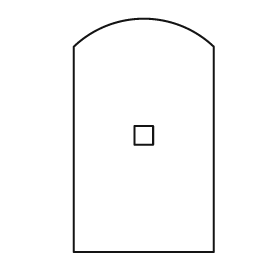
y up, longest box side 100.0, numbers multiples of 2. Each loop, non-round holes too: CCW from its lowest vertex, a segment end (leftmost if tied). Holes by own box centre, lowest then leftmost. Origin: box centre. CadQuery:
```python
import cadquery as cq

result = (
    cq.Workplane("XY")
    .moveTo(-30.0, -50.0)
    .lineTo(30.0, -50.0)
    .lineTo(30.0, 38.0)
    .threePointArc((0.0, 50.0), (-30.0, 38.0))
    .close()
    .moveTo(-4.0, -4.0)
    .lineTo(4.0, -4.0)
    .lineTo(4.0, 4.0)
    .lineTo(-4.0, 4.0)
    .close()
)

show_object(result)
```